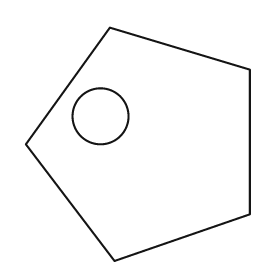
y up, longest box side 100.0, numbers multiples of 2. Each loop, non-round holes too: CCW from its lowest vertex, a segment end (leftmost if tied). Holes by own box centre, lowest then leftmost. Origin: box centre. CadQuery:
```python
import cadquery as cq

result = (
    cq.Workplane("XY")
    .moveTo(-10.0, -50.0)
    .lineTo(48.0, -30.0)
    .lineTo(48.0, 32.0)
    .lineTo(-12.0, 50.0)
    .lineTo(-48.0, 0.0)
    .close()
    .moveTo(-16.0, 12.0)
    .circle(12.0)
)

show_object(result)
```